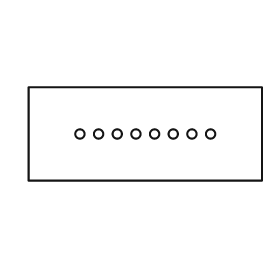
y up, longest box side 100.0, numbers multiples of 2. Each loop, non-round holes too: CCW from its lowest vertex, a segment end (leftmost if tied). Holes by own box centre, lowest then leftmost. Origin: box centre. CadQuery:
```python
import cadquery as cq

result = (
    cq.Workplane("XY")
    .moveTo(-50.0, -20.0)
    .lineTo(50.0, -20.0)
    .lineTo(50.0, 20.0)
    .lineTo(-50.0, 20.0)
    .close()
    .moveTo(-28.0, 0.0)
    .circle(2.0)
    .moveTo(-20.0, 0.0)
    .circle(2.0)
    .moveTo(-12.0, 0.0)
    .circle(2.0)
    .moveTo(-4.0, 0.0)
    .circle(2.0)
    .moveTo(4.0, 0.0)
    .circle(2.0)
    .moveTo(12.0, 0.0)
    .circle(2.0)
    .moveTo(20.0, 0.0)
    .circle(2.0)
    .moveTo(28.0, 0.0)
    .circle(2.0)
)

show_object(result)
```